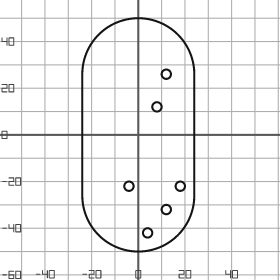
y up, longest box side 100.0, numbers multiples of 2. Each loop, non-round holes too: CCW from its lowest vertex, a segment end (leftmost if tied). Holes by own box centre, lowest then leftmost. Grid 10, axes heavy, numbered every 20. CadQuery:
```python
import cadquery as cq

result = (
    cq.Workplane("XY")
    .moveTo(-24.0, -26.0)
    .threePointArc((0.0, -50.0), (24.0, -26.0))
    .lineTo(24.0, 26.0)
    .threePointArc((0.0, 50.0), (-24.0, 26.0))
    .close()
    .moveTo(4.0, -42.0)
    .circle(2.0)
    .moveTo(12.0, -32.0)
    .circle(2.0)
    .moveTo(-4.0, -22.0)
    .circle(2.0)
    .moveTo(18.0, -22.0)
    .circle(2.0)
    .moveTo(8.0, 12.0)
    .circle(2.0)
    .moveTo(12.0, 26.0)
    .circle(2.0)
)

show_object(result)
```